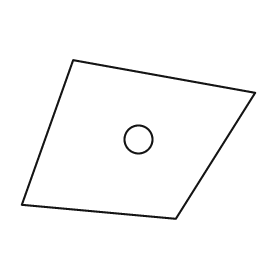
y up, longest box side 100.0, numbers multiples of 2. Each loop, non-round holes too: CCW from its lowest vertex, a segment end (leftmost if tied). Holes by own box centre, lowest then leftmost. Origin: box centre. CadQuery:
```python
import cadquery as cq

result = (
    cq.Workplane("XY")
    .moveTo(16.0, -34.0)
    .lineTo(50.0, 20.0)
    .lineTo(-28.0, 34.0)
    .lineTo(-50.0, -28.0)
    .close()
    .moveTo(0.0, 0.0)
    .circle(6.0)
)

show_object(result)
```